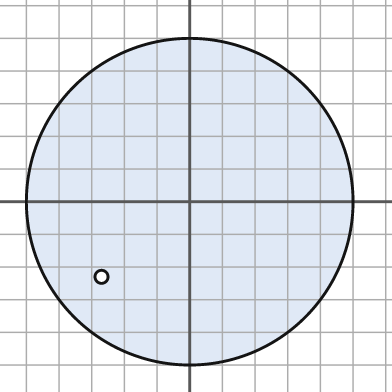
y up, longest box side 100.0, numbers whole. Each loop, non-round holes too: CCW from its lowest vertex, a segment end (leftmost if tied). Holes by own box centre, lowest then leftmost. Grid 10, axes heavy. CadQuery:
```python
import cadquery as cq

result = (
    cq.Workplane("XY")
    .moveTo(0.0, 0.0)
    .circle(50.0)
    .moveTo(-27.0, -23.0)
    .circle(2.0)
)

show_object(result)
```